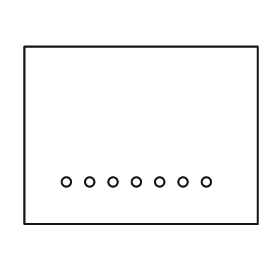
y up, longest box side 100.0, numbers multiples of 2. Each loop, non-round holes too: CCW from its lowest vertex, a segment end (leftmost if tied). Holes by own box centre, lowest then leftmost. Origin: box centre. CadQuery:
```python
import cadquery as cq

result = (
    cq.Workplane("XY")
    .moveTo(-50.0, -38.0)
    .lineTo(50.0, -38.0)
    .lineTo(50.0, 38.0)
    .lineTo(-50.0, 38.0)
    .close()
    .moveTo(-32.0, -20.0)
    .circle(2.0)
    .moveTo(-22.0, -20.0)
    .circle(2.0)
    .moveTo(-12.0, -20.0)
    .circle(2.0)
    .moveTo(-2.0, -20.0)
    .circle(2.0)
    .moveTo(8.0, -20.0)
    .circle(2.0)
    .moveTo(18.0, -20.0)
    .circle(2.0)
    .moveTo(28.0, -20.0)
    .circle(2.0)
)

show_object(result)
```